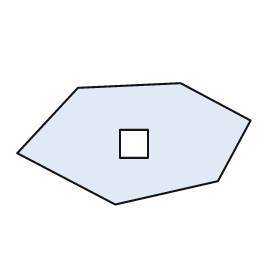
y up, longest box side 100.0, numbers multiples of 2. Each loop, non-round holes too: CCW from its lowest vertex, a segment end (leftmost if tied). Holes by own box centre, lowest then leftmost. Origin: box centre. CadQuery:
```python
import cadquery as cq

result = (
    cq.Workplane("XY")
    .moveTo(-8.0, -26.0)
    .lineTo(36.0, -16.0)
    .lineTo(50.0, 10.0)
    .lineTo(20.0, 26.0)
    .lineTo(-24.0, 24.0)
    .lineTo(-50.0, -4.0)
    .close()
    .moveTo(-6.0, -6.0)
    .lineTo(6.0, -6.0)
    .lineTo(6.0, 6.0)
    .lineTo(-6.0, 6.0)
    .close()
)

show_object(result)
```